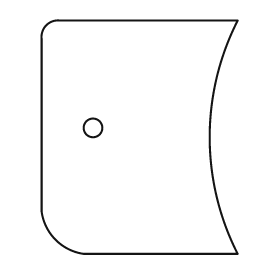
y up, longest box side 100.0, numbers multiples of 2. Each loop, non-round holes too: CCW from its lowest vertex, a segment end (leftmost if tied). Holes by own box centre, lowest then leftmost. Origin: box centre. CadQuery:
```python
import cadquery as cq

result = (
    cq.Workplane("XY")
    .moveTo(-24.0, -50.0)
    .lineTo(42.0, -50.0)
    .threePointArc((30.0, 0.0), (42.0, 50.0))
    .lineTo(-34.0, 50.0)
    .threePointArc((-40.0, 48.0), (-42.0, 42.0))
    .lineTo(-42.0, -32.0)
    .threePointArc((-36.0, -44.0), (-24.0, -50.0))
    .close()
    .moveTo(-20.0, 4.0)
    .circle(4.0)
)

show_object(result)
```